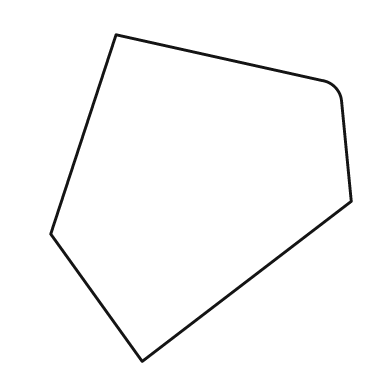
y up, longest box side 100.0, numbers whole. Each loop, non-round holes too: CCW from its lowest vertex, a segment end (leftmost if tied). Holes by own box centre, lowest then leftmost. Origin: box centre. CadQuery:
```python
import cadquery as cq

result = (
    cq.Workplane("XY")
    .moveTo(-18.0, -50.0)
    .lineTo(46.0, -1.0)
    .lineTo(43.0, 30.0)
    .threePointArc((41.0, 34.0), (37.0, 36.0))
    .lineTo(-26.0, 50.0)
    .lineTo(-46.0, -11.0)
    .close()
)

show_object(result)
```